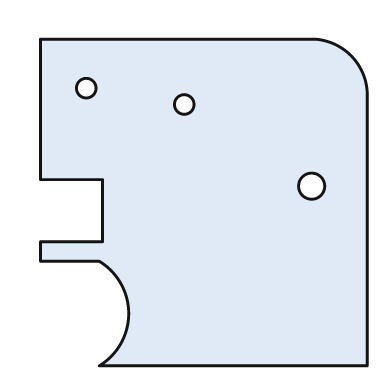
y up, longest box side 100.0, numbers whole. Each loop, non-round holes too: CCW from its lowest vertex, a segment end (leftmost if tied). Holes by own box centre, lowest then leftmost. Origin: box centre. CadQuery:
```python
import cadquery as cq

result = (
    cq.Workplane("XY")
    .moveTo(-32.0, -50.0)
    .lineTo(50.0, -50.0)
    .lineTo(50.0, 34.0)
    .threePointArc((45.0, 45.0), (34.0, 50.0))
    .lineTo(-50.0, 50.0)
    .lineTo(-50.0, 7.0)
    .lineTo(-31.0, 7.0)
    .lineTo(-31.0, -12.0)
    .lineTo(-50.0, -12.0)
    .lineTo(-50.0, -18.0)
    .lineTo(-32.0, -18.0)
    .threePointArc((-23.0, -34.0), (-32.0, -50.0))
    .close()
    .moveTo(33.0, 5.0)
    .circle(4.0)
    .moveTo(-6.0, 30.0)
    .circle(3.0)
    .moveTo(-36.0, 35.0)
    .circle(3.0)
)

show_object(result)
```